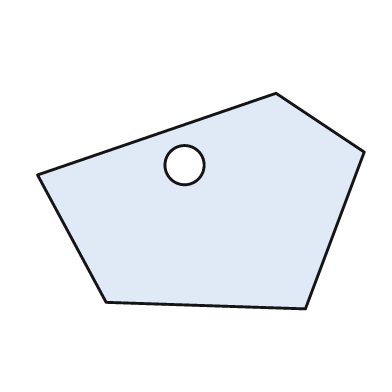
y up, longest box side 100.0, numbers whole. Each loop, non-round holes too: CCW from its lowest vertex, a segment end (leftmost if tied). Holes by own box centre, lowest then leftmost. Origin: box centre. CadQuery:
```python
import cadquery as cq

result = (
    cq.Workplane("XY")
    .moveTo(32.0, -33.0)
    .lineTo(50.0, 15.0)
    .lineTo(23.0, 33.0)
    .lineTo(-50.0, 8.0)
    .lineTo(-29.0, -31.0)
    .close()
    .moveTo(-5.0, 11.0)
    .circle(6.0)
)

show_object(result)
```